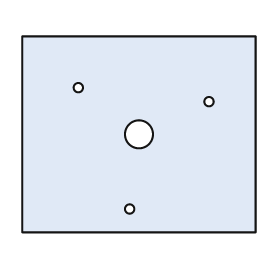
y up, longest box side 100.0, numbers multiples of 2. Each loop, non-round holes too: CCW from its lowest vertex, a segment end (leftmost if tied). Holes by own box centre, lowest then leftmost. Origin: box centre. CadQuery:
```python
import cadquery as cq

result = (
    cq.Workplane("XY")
    .moveTo(-50.0, -42.0)
    .lineTo(50.0, -42.0)
    .lineTo(50.0, 42.0)
    .lineTo(-50.0, 42.0)
    .close()
    .moveTo(-4.0, -32.0)
    .circle(2.0)
    .moveTo(0.0, 0.0)
    .circle(6.0)
    .moveTo(30.0, 14.0)
    .circle(2.0)
    .moveTo(-26.0, 20.0)
    .circle(2.0)
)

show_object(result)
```